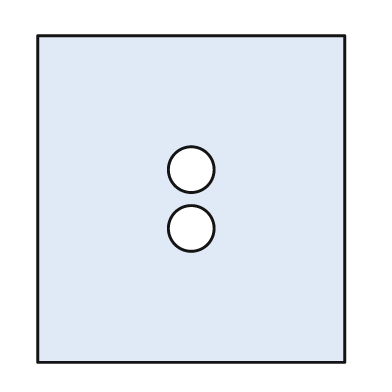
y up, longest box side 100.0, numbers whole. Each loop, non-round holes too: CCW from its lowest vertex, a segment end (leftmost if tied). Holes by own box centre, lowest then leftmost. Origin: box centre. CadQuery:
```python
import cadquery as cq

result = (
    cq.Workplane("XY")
    .moveTo(-47.0, -50.0)
    .lineTo(47.0, -50.0)
    .lineTo(47.0, 50.0)
    .lineTo(-47.0, 50.0)
    .close()
    .moveTo(0.0, -9.0)
    .circle(7.0)
    .moveTo(0.0, 9.0)
    .circle(7.0)
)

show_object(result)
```